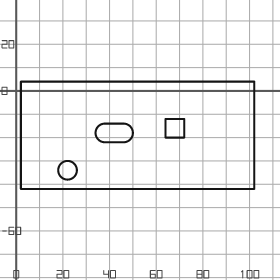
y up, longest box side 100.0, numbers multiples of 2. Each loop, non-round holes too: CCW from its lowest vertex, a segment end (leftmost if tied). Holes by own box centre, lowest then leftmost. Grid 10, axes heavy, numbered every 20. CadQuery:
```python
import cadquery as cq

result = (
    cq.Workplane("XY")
    .moveTo(2.0, -42.0)
    .lineTo(102.0, -42.0)
    .lineTo(102.0, 4.0)
    .lineTo(2.0, 4.0)
    .close()
    .moveTo(22.0, -34.0)
    .circle(4.0)
    .moveTo(38.0, -22.0)
    .lineTo(46.0, -22.0)
    .threePointArc((50.0, -18.0), (46.0, -14.0))
    .lineTo(38.0, -14.0)
    .threePointArc((34.0, -18.0), (38.0, -22.0))
    .close()
    .moveTo(64.0, -20.0)
    .lineTo(72.0, -20.0)
    .lineTo(72.0, -12.0)
    .lineTo(64.0, -12.0)
    .close()
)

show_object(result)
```